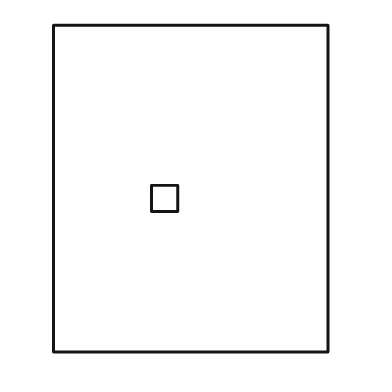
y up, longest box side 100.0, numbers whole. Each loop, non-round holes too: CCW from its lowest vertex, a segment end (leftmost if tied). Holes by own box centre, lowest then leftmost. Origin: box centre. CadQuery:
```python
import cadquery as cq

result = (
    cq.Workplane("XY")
    .moveTo(-42.0, -50.0)
    .lineTo(42.0, -50.0)
    .lineTo(42.0, 50.0)
    .lineTo(-42.0, 50.0)
    .close()
    .moveTo(-12.0, -7.0)
    .lineTo(-4.0, -7.0)
    .lineTo(-4.0, 1.0)
    .lineTo(-12.0, 1.0)
    .close()
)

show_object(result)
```